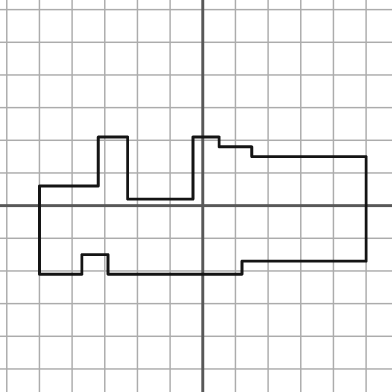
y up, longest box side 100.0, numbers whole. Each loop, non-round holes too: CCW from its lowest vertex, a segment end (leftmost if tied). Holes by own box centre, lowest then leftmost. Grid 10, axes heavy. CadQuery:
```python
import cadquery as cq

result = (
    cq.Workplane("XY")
    .moveTo(-50.0, -21.0)
    .lineTo(-37.0, -21.0)
    .lineTo(-37.0, -15.0)
    .lineTo(-29.0, -15.0)
    .lineTo(-29.0, -21.0)
    .lineTo(12.0, -21.0)
    .lineTo(12.0, -17.0)
    .lineTo(50.0, -17.0)
    .lineTo(50.0, 15.0)
    .lineTo(15.0, 15.0)
    .lineTo(15.0, 18.0)
    .lineTo(5.0, 18.0)
    .lineTo(5.0, 21.0)
    .lineTo(-3.0, 21.0)
    .lineTo(-3.0, 2.0)
    .lineTo(-23.0, 2.0)
    .lineTo(-23.0, 21.0)
    .lineTo(-32.0, 21.0)
    .lineTo(-32.0, 6.0)
    .lineTo(-50.0, 6.0)
    .close()
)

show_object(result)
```